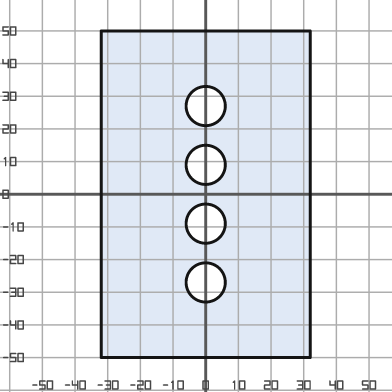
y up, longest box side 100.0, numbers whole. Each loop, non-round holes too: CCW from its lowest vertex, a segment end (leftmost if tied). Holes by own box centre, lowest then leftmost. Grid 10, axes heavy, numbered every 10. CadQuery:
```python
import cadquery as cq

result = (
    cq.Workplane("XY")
    .moveTo(-32.0, -50.0)
    .lineTo(32.0, -50.0)
    .lineTo(32.0, 50.0)
    .lineTo(-32.0, 50.0)
    .close()
    .moveTo(0.0, -27.0)
    .circle(6.0)
    .moveTo(0.0, -9.0)
    .circle(6.0)
    .moveTo(0.0, 9.0)
    .circle(6.0)
    .moveTo(0.0, 27.0)
    .circle(6.0)
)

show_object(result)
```